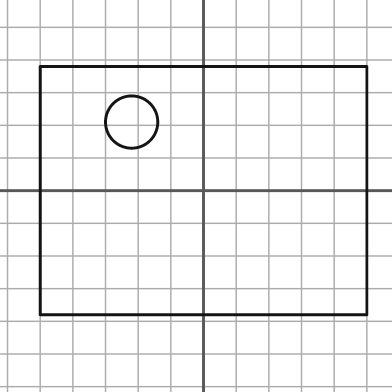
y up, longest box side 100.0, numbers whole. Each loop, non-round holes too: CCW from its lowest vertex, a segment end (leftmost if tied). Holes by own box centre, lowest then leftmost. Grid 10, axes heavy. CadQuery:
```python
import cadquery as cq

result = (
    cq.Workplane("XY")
    .moveTo(-50.0, -38.0)
    .lineTo(50.0, -38.0)
    .lineTo(50.0, 38.0)
    .lineTo(-50.0, 38.0)
    .close()
    .moveTo(-22.0, 21.0)
    .circle(8.0)
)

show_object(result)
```